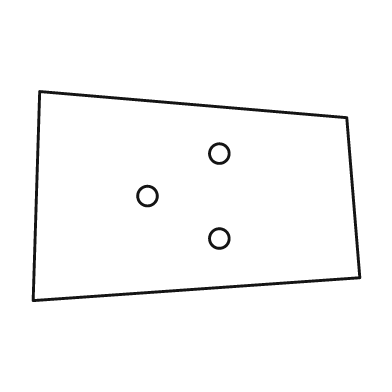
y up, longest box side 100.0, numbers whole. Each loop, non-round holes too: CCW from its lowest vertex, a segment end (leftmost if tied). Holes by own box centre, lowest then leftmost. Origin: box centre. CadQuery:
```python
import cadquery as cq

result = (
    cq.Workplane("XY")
    .moveTo(-50.0, -32.0)
    .lineTo(50.0, -25.0)
    .lineTo(46.0, 24.0)
    .lineTo(-48.0, 32.0)
    .close()
    .moveTo(7.0, -13.0)
    .circle(3.0)
    .moveTo(-15.0, 0.0)
    .circle(3.0)
    .moveTo(7.0, 13.0)
    .circle(3.0)
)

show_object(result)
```